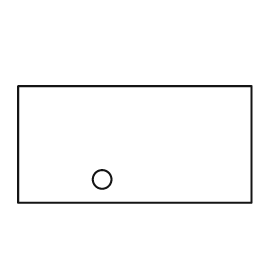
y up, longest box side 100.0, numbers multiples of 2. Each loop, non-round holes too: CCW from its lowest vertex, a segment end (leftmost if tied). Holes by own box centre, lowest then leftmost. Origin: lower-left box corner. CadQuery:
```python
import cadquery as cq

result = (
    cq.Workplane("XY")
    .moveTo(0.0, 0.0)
    .lineTo(100.0, 0.0)
    .lineTo(100.0, 50.0)
    .lineTo(0.0, 50.0)
    .close()
    .moveTo(36.0, 10.0)
    .circle(4.0)
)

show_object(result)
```